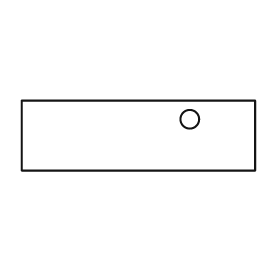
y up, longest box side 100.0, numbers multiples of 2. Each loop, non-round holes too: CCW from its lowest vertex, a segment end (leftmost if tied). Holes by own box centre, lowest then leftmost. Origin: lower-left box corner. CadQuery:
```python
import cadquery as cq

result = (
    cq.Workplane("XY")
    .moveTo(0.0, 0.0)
    .lineTo(100.0, 0.0)
    .lineTo(100.0, 30.0)
    .lineTo(0.0, 30.0)
    .close()
    .moveTo(72.0, 22.0)
    .circle(4.0)
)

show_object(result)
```